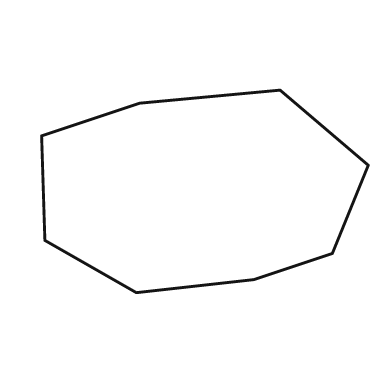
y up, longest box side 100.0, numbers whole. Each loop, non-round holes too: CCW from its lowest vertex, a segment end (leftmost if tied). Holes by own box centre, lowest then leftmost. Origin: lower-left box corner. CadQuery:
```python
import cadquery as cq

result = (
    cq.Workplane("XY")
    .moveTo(29.0, 0.0)
    .lineTo(65.0, 4.0)
    .lineTo(89.0, 12.0)
    .lineTo(100.0, 39.0)
    .lineTo(73.0, 62.0)
    .lineTo(30.0, 58.0)
    .lineTo(0.0, 48.0)
    .lineTo(1.0, 16.0)
    .close()
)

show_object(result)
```